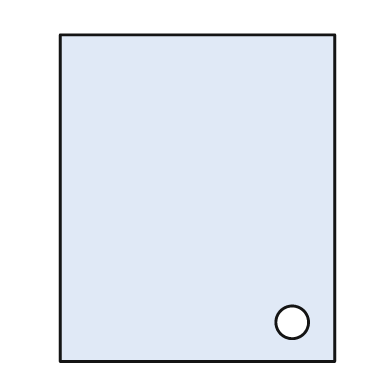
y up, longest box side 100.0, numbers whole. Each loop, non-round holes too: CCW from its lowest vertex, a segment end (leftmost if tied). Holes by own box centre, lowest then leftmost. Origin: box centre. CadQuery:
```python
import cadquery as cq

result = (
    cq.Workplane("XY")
    .moveTo(-42.0, -50.0)
    .lineTo(42.0, -50.0)
    .lineTo(42.0, 50.0)
    .lineTo(-42.0, 50.0)
    .close()
    .moveTo(29.0, -38.0)
    .circle(5.0)
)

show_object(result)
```